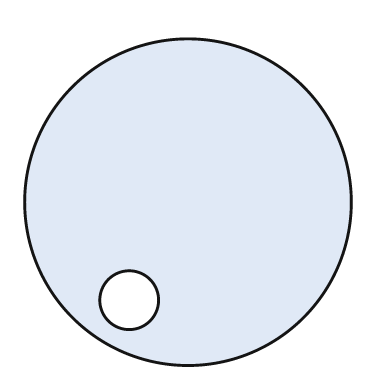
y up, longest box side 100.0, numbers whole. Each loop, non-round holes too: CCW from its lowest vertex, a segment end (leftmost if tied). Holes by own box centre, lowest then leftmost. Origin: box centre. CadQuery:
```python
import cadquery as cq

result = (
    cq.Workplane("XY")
    .moveTo(0.0, 0.0)
    .circle(50.0)
    .moveTo(-18.0, -30.0)
    .circle(9.0)
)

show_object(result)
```